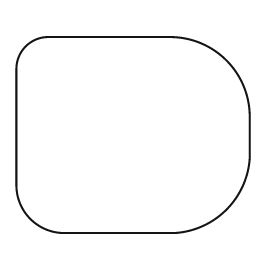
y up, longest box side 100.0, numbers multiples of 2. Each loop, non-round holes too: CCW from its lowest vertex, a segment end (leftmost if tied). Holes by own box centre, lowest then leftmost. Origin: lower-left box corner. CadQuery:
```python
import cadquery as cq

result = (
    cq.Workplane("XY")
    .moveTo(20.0, 0.0)
    .lineTo(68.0, 0.0)
    .threePointArc((90.0, 10.0), (100.0, 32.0))
    .lineTo(100.0, 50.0)
    .threePointArc((90.0, 74.0), (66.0, 84.0))
    .lineTo(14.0, 84.0)
    .threePointArc((4.0, 80.0), (0.0, 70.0))
    .lineTo(0.0, 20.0)
    .threePointArc((6.0, 6.0), (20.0, 0.0))
    .close()
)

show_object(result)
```